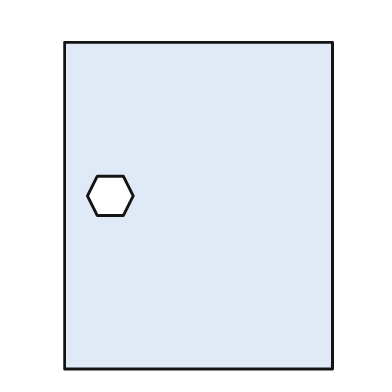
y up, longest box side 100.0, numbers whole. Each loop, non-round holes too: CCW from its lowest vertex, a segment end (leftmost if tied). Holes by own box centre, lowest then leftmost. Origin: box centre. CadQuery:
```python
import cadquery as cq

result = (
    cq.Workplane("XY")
    .moveTo(-41.0, -50.0)
    .lineTo(41.0, -50.0)
    .lineTo(41.0, 50.0)
    .lineTo(-41.0, 50.0)
    .close()
    .moveTo(-31.0, -3.0)
    .lineTo(-23.0, -3.0)
    .lineTo(-20.0, 3.0)
    .lineTo(-23.0, 9.0)
    .lineTo(-31.0, 9.0)
    .lineTo(-34.0, 3.0)
    .close()
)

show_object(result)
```